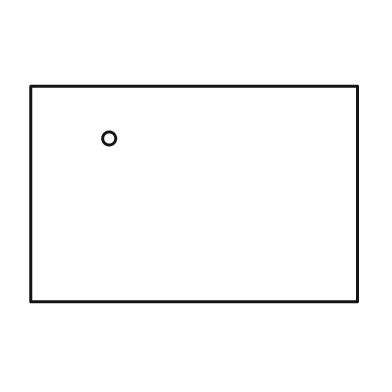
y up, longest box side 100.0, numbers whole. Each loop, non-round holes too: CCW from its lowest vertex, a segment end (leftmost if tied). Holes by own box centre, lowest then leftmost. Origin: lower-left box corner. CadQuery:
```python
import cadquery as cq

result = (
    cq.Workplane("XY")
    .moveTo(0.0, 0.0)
    .lineTo(100.0, 0.0)
    .lineTo(100.0, 66.0)
    .lineTo(0.0, 66.0)
    .close()
    .moveTo(24.0, 50.0)
    .circle(2.0)
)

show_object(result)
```